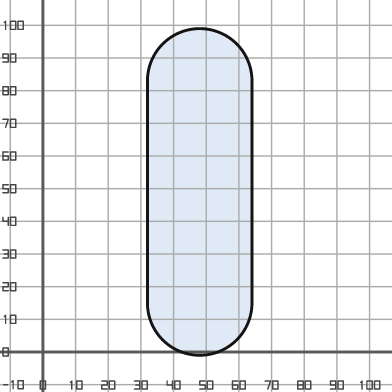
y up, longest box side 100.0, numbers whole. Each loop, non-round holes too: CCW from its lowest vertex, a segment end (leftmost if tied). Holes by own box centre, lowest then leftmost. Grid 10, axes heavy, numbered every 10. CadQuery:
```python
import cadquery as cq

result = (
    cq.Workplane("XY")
    .moveTo(32.0, 15.0)
    .threePointArc((48.0, -1.0), (64.0, 15.0))
    .lineTo(64.0, 83.0)
    .threePointArc((48.0, 99.0), (32.0, 83.0))
    .close()
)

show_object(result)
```